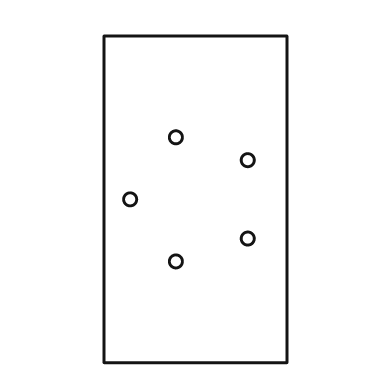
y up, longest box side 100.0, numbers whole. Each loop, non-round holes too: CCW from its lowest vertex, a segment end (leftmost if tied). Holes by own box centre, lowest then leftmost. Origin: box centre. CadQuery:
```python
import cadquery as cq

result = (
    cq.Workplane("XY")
    .moveTo(-28.0, -50.0)
    .lineTo(28.0, -50.0)
    .lineTo(28.0, 50.0)
    .lineTo(-28.0, 50.0)
    .close()
    .moveTo(-6.0, -19.0)
    .circle(2.0)
    .moveTo(16.0, -12.0)
    .circle(2.0)
    .moveTo(-20.0, 0.0)
    .circle(2.0)
    .moveTo(16.0, 12.0)
    .circle(2.0)
    .moveTo(-6.0, 19.0)
    .circle(2.0)
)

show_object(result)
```